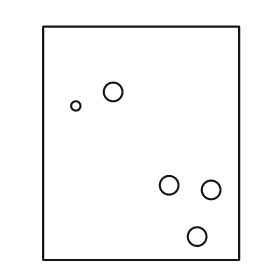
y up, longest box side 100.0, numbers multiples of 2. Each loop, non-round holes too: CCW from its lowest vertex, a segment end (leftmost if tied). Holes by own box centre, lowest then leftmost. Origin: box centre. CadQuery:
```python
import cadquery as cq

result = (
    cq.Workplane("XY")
    .moveTo(-42.0, -50.0)
    .lineTo(42.0, -50.0)
    .lineTo(42.0, 50.0)
    .lineTo(-42.0, 50.0)
    .close()
    .moveTo(24.0, -40.0)
    .circle(4.0)
    .moveTo(30.0, -20.0)
    .circle(4.0)
    .moveTo(12.0, -18.0)
    .circle(4.0)
    .moveTo(-28.0, 16.0)
    .circle(2.0)
    .moveTo(-12.0, 22.0)
    .circle(4.0)
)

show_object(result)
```